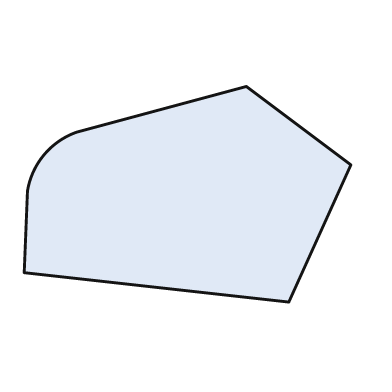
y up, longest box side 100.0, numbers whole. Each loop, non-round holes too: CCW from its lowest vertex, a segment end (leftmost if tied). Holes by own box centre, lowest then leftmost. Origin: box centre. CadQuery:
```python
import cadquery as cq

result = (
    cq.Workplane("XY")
    .moveTo(31.0, -33.0)
    .lineTo(50.0, 9.0)
    .lineTo(18.0, 33.0)
    .lineTo(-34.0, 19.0)
    .threePointArc((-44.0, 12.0), (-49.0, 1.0))
    .lineTo(-50.0, -24.0)
    .close()
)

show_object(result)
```